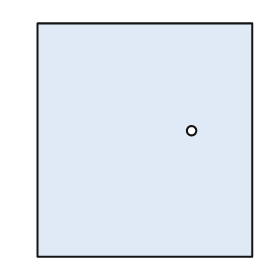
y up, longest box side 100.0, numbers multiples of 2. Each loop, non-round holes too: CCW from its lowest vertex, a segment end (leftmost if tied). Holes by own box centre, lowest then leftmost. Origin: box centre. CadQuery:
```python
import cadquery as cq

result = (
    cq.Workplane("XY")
    .moveTo(-46.0, -50.0)
    .lineTo(46.0, -50.0)
    .lineTo(46.0, 50.0)
    .lineTo(-46.0, 50.0)
    .close()
    .moveTo(20.0, 4.0)
    .circle(2.0)
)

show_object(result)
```